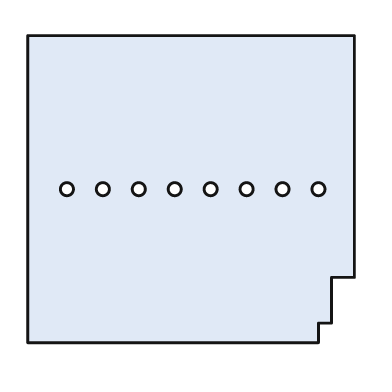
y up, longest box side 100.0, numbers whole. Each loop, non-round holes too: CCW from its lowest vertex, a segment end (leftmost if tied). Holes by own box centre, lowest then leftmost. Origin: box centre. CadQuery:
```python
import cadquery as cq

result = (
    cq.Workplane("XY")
    .moveTo(-50.0, -47.0)
    .lineTo(39.0, -47.0)
    .lineTo(39.0, -41.0)
    .lineTo(43.0, -41.0)
    .lineTo(43.0, -27.0)
    .lineTo(50.0, -27.0)
    .lineTo(50.0, 47.0)
    .lineTo(-50.0, 47.0)
    .close()
    .moveTo(-38.0, 0.0)
    .circle(2.0)
    .moveTo(-27.0, 0.0)
    .circle(2.0)
    .moveTo(-16.0, 0.0)
    .circle(2.0)
    .moveTo(-5.0, 0.0)
    .circle(2.0)
    .moveTo(6.0, 0.0)
    .circle(2.0)
    .moveTo(17.0, 0.0)
    .circle(2.0)
    .moveTo(28.0, 0.0)
    .circle(2.0)
    .moveTo(39.0, 0.0)
    .circle(2.0)
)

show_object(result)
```